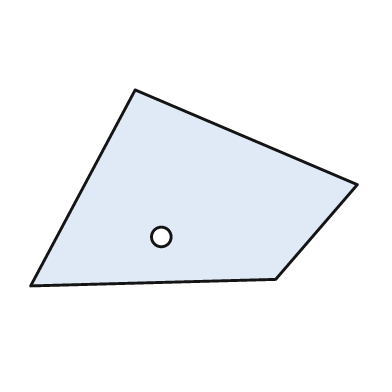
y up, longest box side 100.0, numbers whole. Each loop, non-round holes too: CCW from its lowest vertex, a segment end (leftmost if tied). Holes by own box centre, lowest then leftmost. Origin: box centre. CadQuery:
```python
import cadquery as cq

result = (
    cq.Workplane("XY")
    .moveTo(-50.0, -30.0)
    .lineTo(25.0, -28.0)
    .lineTo(50.0, 1.0)
    .lineTo(-18.0, 30.0)
    .close()
    .moveTo(-10.0, -15.0)
    .circle(3.0)
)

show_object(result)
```